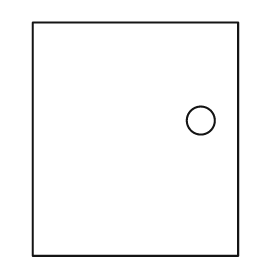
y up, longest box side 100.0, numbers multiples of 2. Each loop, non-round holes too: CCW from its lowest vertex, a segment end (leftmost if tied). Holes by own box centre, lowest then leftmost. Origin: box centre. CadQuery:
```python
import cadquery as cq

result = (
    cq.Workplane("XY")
    .moveTo(-44.0, -50.0)
    .lineTo(44.0, -50.0)
    .lineTo(44.0, 50.0)
    .lineTo(-44.0, 50.0)
    .close()
    .moveTo(28.0, 8.0)
    .circle(6.0)
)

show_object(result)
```